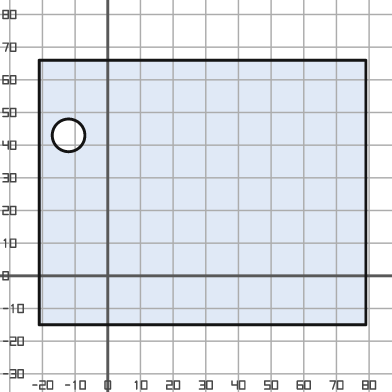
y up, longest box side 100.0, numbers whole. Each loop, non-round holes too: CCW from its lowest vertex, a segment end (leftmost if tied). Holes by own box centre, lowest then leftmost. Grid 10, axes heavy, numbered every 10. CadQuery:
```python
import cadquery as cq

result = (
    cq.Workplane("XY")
    .moveTo(-21.0, -15.0)
    .lineTo(79.0, -15.0)
    .lineTo(79.0, 66.0)
    .lineTo(-21.0, 66.0)
    .close()
    .moveTo(-12.0, 43.0)
    .circle(5.0)
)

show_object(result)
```